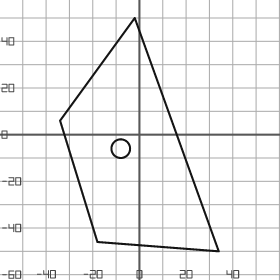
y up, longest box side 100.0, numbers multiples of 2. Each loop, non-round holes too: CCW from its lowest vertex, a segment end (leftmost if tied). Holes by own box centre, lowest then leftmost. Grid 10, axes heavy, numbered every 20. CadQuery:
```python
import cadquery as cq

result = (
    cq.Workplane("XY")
    .moveTo(34.0, -50.0)
    .lineTo(-2.0, 50.0)
    .lineTo(-34.0, 6.0)
    .lineTo(-18.0, -46.0)
    .close()
    .moveTo(-8.0, -6.0)
    .circle(4.0)
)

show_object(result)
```